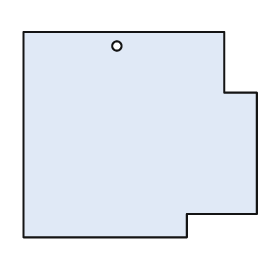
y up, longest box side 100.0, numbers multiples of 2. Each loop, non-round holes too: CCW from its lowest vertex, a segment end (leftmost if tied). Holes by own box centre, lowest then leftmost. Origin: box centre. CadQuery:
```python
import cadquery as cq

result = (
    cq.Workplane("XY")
    .moveTo(-50.0, -44.0)
    .lineTo(20.0, -44.0)
    .lineTo(20.0, -34.0)
    .lineTo(50.0, -34.0)
    .lineTo(50.0, 18.0)
    .lineTo(36.0, 18.0)
    .lineTo(36.0, 44.0)
    .lineTo(-50.0, 44.0)
    .close()
    .moveTo(-10.0, 38.0)
    .circle(2.0)
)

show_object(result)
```